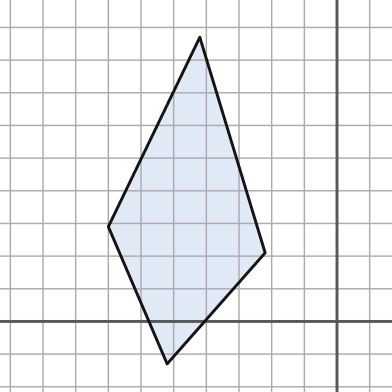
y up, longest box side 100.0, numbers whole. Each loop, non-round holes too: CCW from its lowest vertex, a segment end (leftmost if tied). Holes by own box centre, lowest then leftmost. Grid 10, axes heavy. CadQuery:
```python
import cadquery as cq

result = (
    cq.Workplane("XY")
    .moveTo(-52.0, -13.0)
    .lineTo(-22.0, 21.0)
    .lineTo(-42.0, 87.0)
    .lineTo(-70.0, 29.0)
    .close()
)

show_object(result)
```